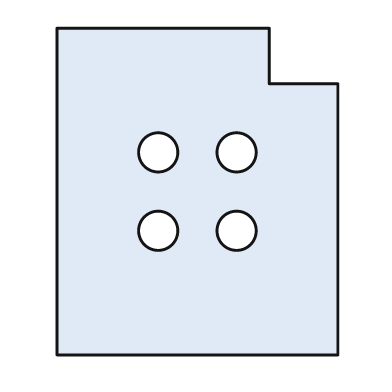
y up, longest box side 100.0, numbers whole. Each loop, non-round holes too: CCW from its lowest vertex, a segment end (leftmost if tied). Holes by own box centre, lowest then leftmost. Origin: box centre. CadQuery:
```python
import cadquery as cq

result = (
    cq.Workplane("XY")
    .moveTo(-43.0, -50.0)
    .lineTo(43.0, -50.0)
    .lineTo(43.0, 33.0)
    .lineTo(22.0, 33.0)
    .lineTo(22.0, 50.0)
    .lineTo(-43.0, 50.0)
    .close()
    .moveTo(-12.0, -12.0)
    .circle(6.0)
    .moveTo(12.0, -12.0)
    .circle(6.0)
    .moveTo(-12.0, 12.0)
    .circle(6.0)
    .moveTo(12.0, 12.0)
    .circle(6.0)
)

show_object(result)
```